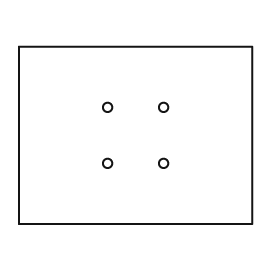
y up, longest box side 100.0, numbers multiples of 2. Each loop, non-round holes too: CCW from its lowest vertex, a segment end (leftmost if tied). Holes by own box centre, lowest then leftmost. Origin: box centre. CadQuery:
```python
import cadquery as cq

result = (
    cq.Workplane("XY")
    .moveTo(-50.0, -38.0)
    .lineTo(50.0, -38.0)
    .lineTo(50.0, 38.0)
    .lineTo(-50.0, 38.0)
    .close()
    .moveTo(-12.0, -12.0)
    .circle(2.0)
    .moveTo(12.0, -12.0)
    .circle(2.0)
    .moveTo(-12.0, 12.0)
    .circle(2.0)
    .moveTo(12.0, 12.0)
    .circle(2.0)
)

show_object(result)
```